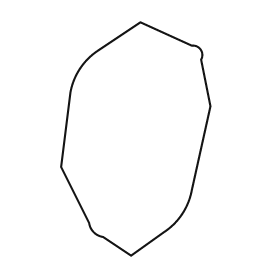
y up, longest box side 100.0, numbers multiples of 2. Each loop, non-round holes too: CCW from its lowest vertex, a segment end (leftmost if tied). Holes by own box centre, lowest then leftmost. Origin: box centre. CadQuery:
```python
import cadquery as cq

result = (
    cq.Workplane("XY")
    .moveTo(-2.0, -50.0)
    .lineTo(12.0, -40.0)
    .threePointArc((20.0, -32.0), (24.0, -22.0))
    .lineTo(32.0, 14.0)
    .lineTo(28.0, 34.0)
    .threePointArc((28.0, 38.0), (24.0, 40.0))
    .lineTo(2.0, 50.0)
    .lineTo(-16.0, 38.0)
    .threePointArc((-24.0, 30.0), (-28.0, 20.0))
    .lineTo(-32.0, -12.0)
    .lineTo(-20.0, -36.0)
    .threePointArc((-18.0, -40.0), (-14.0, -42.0))
    .close()
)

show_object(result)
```